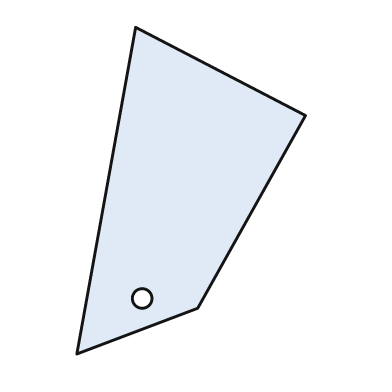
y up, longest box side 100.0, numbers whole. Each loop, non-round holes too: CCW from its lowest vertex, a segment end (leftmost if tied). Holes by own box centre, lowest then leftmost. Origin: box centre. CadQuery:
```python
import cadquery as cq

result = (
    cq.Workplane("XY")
    .moveTo(-35.0, -50.0)
    .lineTo(2.0, -36.0)
    .lineTo(35.0, 23.0)
    .lineTo(-17.0, 50.0)
    .close()
    .moveTo(-15.0, -33.0)
    .circle(3.0)
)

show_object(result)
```